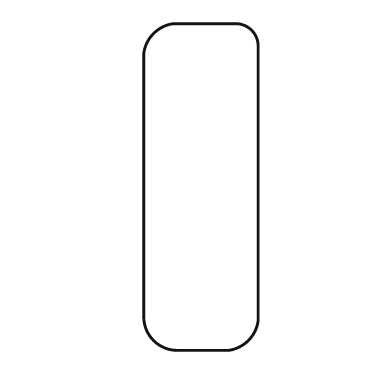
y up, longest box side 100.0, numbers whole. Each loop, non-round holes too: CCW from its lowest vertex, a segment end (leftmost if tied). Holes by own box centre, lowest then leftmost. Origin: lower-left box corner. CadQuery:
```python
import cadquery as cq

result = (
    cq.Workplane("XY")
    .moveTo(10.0, 0.0)
    .lineTo(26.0, 0.0)
    .threePointArc((32.0, 3.0), (35.0, 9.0))
    .lineTo(35.0, 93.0)
    .threePointArc((33.0, 98.0), (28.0, 100.0))
    .lineTo(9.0, 100.0)
    .threePointArc((3.0, 97.0), (0.0, 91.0))
    .lineTo(0.0, 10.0)
    .threePointArc((3.0, 3.0), (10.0, 0.0))
    .close()
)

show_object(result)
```